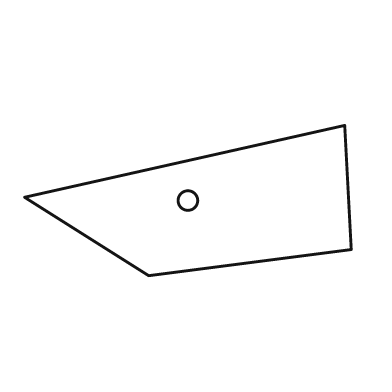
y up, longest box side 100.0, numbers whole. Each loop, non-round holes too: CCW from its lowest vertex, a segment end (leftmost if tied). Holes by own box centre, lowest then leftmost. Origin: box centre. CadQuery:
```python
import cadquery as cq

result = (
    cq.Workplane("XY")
    .moveTo(-12.0, -23.0)
    .lineTo(50.0, -15.0)
    .lineTo(48.0, 23.0)
    .lineTo(-50.0, 1.0)
    .close()
    .moveTo(0.0, 0.0)
    .circle(3.0)
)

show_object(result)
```